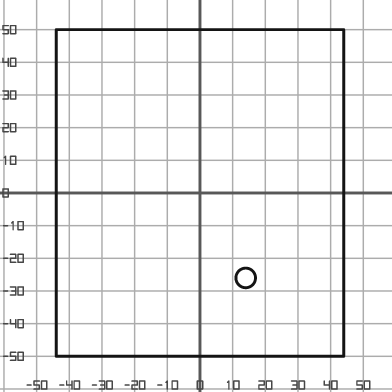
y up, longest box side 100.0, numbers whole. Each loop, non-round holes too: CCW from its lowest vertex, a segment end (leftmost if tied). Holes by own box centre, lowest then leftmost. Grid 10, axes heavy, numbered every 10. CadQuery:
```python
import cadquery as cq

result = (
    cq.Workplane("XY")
    .moveTo(-44.0, -50.0)
    .lineTo(44.0, -50.0)
    .lineTo(44.0, 50.0)
    .lineTo(-44.0, 50.0)
    .close()
    .moveTo(14.0, -26.0)
    .circle(3.0)
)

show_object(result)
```